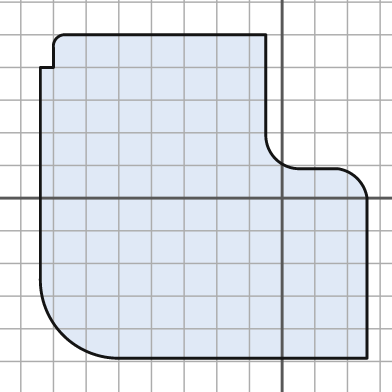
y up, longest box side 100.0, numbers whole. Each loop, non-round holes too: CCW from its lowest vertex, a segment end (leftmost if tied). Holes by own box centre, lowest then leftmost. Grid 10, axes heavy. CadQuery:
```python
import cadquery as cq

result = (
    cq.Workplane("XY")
    .moveTo(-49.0, -49.0)
    .lineTo(26.0, -49.0)
    .lineTo(26.0, 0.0)
    .threePointArc((23.0, 6.0), (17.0, 9.0))
    .lineTo(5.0, 9.0)
    .threePointArc((-2.0, 12.0), (-5.0, 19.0))
    .lineTo(-5.0, 50.0)
    .lineTo(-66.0, 50.0)
    .threePointArc((-69.0, 49.0), (-70.0, 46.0))
    .lineTo(-70.0, 40.0)
    .lineTo(-74.0, 40.0)
    .lineTo(-74.0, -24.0)
    .threePointArc((-67.0, -42.0), (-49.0, -49.0))
    .close()
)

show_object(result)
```